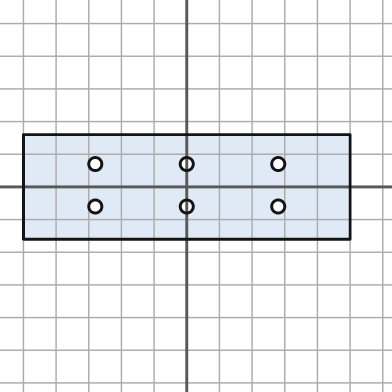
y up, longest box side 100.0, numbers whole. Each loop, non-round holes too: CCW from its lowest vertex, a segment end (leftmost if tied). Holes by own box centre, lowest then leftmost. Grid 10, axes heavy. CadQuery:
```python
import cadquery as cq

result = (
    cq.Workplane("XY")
    .moveTo(-50.0, -16.0)
    .lineTo(50.0, -16.0)
    .lineTo(50.0, 16.0)
    .lineTo(-50.0, 16.0)
    .close()
    .moveTo(-28.0, -6.0)
    .circle(2.0)
    .moveTo(0.0, -6.0)
    .circle(2.0)
    .moveTo(28.0, -6.0)
    .circle(2.0)
    .moveTo(-28.0, 7.0)
    .circle(2.0)
    .moveTo(0.0, 7.0)
    .circle(2.0)
    .moveTo(28.0, 7.0)
    .circle(2.0)
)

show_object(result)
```